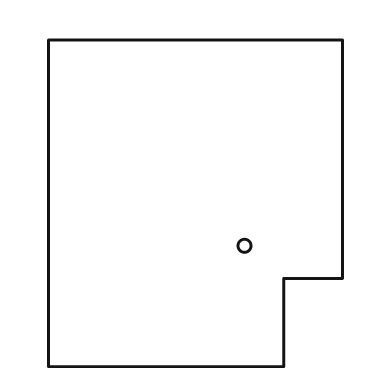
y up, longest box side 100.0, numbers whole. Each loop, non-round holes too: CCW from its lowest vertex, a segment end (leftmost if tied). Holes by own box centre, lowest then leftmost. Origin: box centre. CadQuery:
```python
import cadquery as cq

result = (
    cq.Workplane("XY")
    .moveTo(-45.0, -50.0)
    .lineTo(27.0, -50.0)
    .lineTo(27.0, -23.0)
    .lineTo(45.0, -23.0)
    .lineTo(45.0, 50.0)
    .lineTo(-45.0, 50.0)
    .close()
    .moveTo(15.0, -13.0)
    .circle(2.0)
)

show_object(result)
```